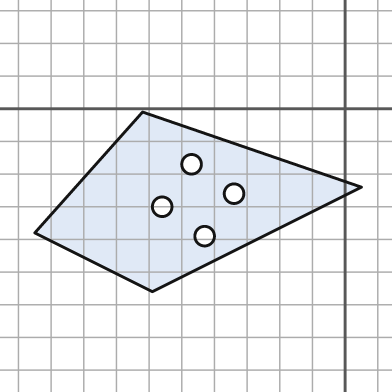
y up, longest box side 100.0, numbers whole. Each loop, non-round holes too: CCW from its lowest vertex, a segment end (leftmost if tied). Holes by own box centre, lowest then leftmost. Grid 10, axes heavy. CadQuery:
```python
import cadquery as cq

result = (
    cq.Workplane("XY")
    .moveTo(-59.0, -56.0)
    .lineTo(5.0, -24.0)
    .lineTo(-62.0, -1.0)
    .lineTo(-95.0, -38.0)
    .close()
    .moveTo(-43.0, -39.0)
    .circle(3.0)
    .moveTo(-56.0, -30.0)
    .circle(3.0)
    .moveTo(-34.0, -26.0)
    .circle(3.0)
    .moveTo(-47.0, -17.0)
    .circle(3.0)
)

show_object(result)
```